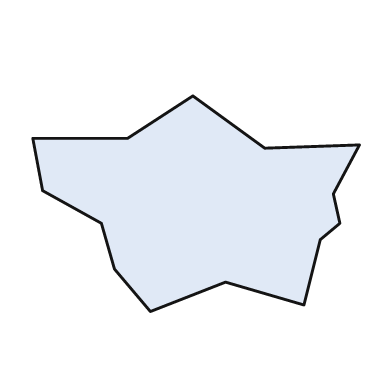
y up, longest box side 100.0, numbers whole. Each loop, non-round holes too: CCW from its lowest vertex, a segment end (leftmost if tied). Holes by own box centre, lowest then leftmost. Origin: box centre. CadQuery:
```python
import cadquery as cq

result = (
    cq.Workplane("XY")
    .moveTo(-14.0, -33.0)
    .lineTo(9.0, -24.0)
    .lineTo(33.0, -31.0)
    .lineTo(38.0, -11.0)
    .lineTo(44.0, -6.0)
    .lineTo(42.0, 3.0)
    .lineTo(50.0, 18.0)
    .lineTo(21.0, 17.0)
    .lineTo(-1.0, 33.0)
    .lineTo(-21.0, 20.0)
    .lineTo(-50.0, 20.0)
    .lineTo(-47.0, 4.0)
    .lineTo(-29.0, -6.0)
    .lineTo(-25.0, -20.0)
    .close()
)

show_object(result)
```